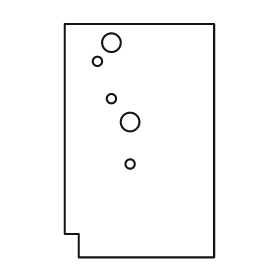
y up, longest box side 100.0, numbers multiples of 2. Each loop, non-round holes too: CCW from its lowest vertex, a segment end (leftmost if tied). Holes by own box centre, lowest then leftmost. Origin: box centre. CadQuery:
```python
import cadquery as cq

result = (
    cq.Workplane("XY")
    .moveTo(-26.0, -50.0)
    .lineTo(32.0, -50.0)
    .lineTo(32.0, 50.0)
    .lineTo(-32.0, 50.0)
    .lineTo(-32.0, -40.0)
    .lineTo(-26.0, -40.0)
    .close()
    .moveTo(-4.0, -10.0)
    .circle(2.0)
    .moveTo(-4.0, 8.0)
    .circle(4.0)
    .moveTo(-12.0, 18.0)
    .circle(2.0)
    .moveTo(-18.0, 34.0)
    .circle(2.0)
    .moveTo(-12.0, 42.0)
    .circle(4.0)
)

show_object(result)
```